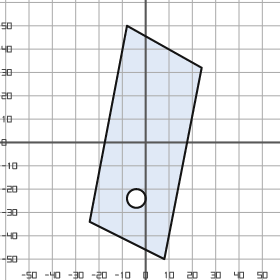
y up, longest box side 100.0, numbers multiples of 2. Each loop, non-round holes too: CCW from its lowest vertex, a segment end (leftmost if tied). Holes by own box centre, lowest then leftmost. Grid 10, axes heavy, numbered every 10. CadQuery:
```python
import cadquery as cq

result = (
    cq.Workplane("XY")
    .moveTo(8.0, -50.0)
    .lineTo(24.0, 32.0)
    .lineTo(-8.0, 50.0)
    .lineTo(-24.0, -34.0)
    .close()
    .moveTo(-4.0, -24.0)
    .circle(4.0)
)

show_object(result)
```